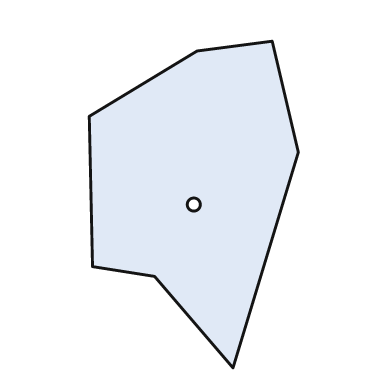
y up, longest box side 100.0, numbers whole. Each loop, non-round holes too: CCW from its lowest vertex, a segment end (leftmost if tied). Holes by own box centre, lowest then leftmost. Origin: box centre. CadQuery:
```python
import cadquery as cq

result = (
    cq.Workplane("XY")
    .moveTo(12.0, -50.0)
    .lineTo(32.0, 16.0)
    .lineTo(24.0, 50.0)
    .lineTo(1.0, 47.0)
    .lineTo(-32.0, 27.0)
    .lineTo(-31.0, -19.0)
    .lineTo(-12.0, -22.0)
    .close()
    .moveTo(0.0, 0.0)
    .circle(2.0)
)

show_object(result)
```